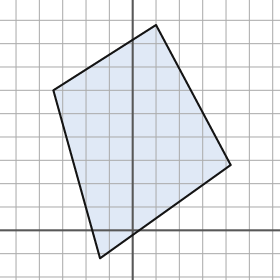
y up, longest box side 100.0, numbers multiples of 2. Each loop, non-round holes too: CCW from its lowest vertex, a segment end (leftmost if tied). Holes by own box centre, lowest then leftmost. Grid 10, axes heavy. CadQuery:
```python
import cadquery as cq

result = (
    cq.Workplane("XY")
    .moveTo(-14.0, -12.0)
    .lineTo(42.0, 28.0)
    .lineTo(10.0, 88.0)
    .lineTo(-34.0, 60.0)
    .close()
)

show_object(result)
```